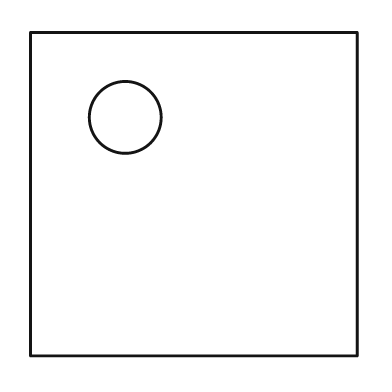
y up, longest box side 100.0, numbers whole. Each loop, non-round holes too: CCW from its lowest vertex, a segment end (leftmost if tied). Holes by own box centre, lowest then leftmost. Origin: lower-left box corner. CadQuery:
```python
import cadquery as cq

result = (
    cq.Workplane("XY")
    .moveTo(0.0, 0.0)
    .lineTo(100.0, 0.0)
    .lineTo(100.0, 99.0)
    .lineTo(0.0, 99.0)
    .close()
    .moveTo(29.0, 73.0)
    .circle(11.0)
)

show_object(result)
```